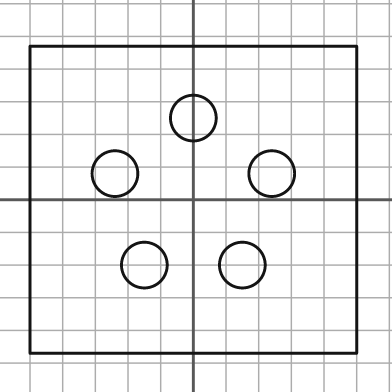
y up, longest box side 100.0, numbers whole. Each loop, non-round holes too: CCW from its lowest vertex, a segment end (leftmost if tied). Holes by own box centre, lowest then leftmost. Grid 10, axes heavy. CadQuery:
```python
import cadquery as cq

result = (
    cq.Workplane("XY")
    .moveTo(-50.0, -47.0)
    .lineTo(50.0, -47.0)
    .lineTo(50.0, 47.0)
    .lineTo(-50.0, 47.0)
    .close()
    .moveTo(-15.0, -20.0)
    .circle(7.0)
    .moveTo(15.0, -20.0)
    .circle(7.0)
    .moveTo(-24.0, 8.0)
    .circle(7.0)
    .moveTo(24.0, 8.0)
    .circle(7.0)
    .moveTo(0.0, 25.0)
    .circle(7.0)
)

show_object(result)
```